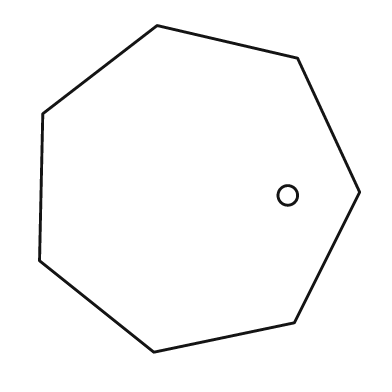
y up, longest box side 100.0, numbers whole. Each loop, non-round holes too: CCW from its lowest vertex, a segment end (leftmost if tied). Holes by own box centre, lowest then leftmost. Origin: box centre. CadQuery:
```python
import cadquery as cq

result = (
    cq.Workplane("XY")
    .moveTo(-14.0, -50.0)
    .lineTo(29.0, -41.0)
    .lineTo(49.0, -1.0)
    .lineTo(30.0, 40.0)
    .lineTo(-13.0, 50.0)
    .lineTo(-48.0, 23.0)
    .lineTo(-49.0, -22.0)
    .close()
    .moveTo(27.0, -2.0)
    .circle(3.0)
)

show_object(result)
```